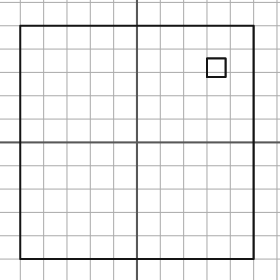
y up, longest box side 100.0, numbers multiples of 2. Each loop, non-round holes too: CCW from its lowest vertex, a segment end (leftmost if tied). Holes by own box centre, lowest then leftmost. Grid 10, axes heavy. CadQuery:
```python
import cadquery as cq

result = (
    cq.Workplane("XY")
    .moveTo(-50.0, -50.0)
    .lineTo(50.0, -50.0)
    .lineTo(50.0, 50.0)
    .lineTo(-50.0, 50.0)
    .close()
    .moveTo(30.0, 28.0)
    .lineTo(38.0, 28.0)
    .lineTo(38.0, 36.0)
    .lineTo(30.0, 36.0)
    .close()
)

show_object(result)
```